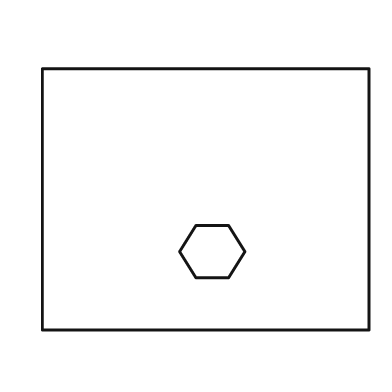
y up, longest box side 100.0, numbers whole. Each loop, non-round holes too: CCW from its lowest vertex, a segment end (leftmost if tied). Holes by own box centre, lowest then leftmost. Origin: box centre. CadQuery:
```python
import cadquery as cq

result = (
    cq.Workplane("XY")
    .moveTo(-50.0, -40.0)
    .lineTo(50.0, -40.0)
    .lineTo(50.0, 40.0)
    .lineTo(-50.0, 40.0)
    .close()
    .moveTo(-3.0, -24.0)
    .lineTo(7.0, -24.0)
    .lineTo(12.0, -16.0)
    .lineTo(7.0, -8.0)
    .lineTo(-3.0, -8.0)
    .lineTo(-8.0, -16.0)
    .close()
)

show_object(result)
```